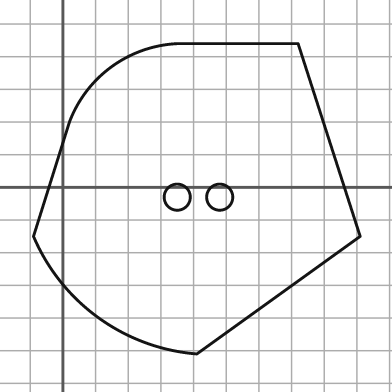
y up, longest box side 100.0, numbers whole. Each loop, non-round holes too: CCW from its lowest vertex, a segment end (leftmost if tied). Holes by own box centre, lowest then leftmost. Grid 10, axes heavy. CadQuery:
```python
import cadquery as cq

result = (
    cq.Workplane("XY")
    .moveTo(41.0, -51.0)
    .lineTo(91.0, -15.0)
    .lineTo(72.0, 44.0)
    .lineTo(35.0, 44.0)
    .threePointArc((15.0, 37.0), (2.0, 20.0))
    .lineTo(-9.0, -15.0)
    .threePointArc((11.0, -40.0), (41.0, -51.0))
    .close()
    .moveTo(35.0, -3.0)
    .circle(4.0)
    .moveTo(48.0, -3.0)
    .circle(4.0)
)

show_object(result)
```